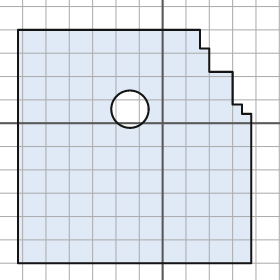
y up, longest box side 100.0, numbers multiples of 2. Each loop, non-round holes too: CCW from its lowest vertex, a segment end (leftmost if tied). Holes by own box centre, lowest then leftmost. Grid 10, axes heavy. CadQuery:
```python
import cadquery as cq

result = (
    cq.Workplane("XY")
    .moveTo(-62.0, -60.0)
    .lineTo(38.0, -60.0)
    .lineTo(38.0, 4.0)
    .lineTo(34.0, 4.0)
    .lineTo(34.0, 8.0)
    .lineTo(30.0, 8.0)
    .lineTo(30.0, 22.0)
    .lineTo(20.0, 22.0)
    .lineTo(20.0, 32.0)
    .lineTo(16.0, 32.0)
    .lineTo(16.0, 40.0)
    .lineTo(-62.0, 40.0)
    .close()
    .moveTo(-14.0, 6.0)
    .circle(8.0)
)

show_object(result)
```